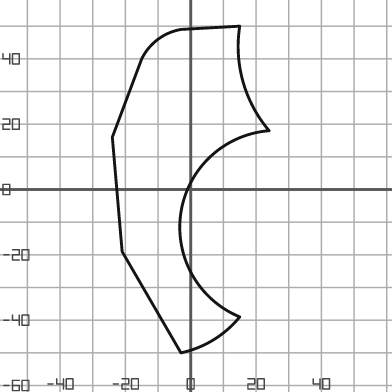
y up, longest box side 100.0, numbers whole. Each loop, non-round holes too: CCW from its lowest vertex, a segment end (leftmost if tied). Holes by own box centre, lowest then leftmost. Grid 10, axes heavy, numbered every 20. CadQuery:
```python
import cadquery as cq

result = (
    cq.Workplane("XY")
    .moveTo(-3.0, -50.0)
    .threePointArc((7.0, -46.0), (15.0, -39.0))
    .threePointArc((-3.0, -7.0), (24.0, 18.0))
    .threePointArc((16.0, 33.0), (15.0, 50.0))
    .lineTo(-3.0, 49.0)
    .threePointArc((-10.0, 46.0), (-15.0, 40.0))
    .lineTo(-24.0, 16.0)
    .lineTo(-21.0, -19.0)
    .close()
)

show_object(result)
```